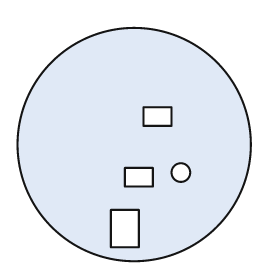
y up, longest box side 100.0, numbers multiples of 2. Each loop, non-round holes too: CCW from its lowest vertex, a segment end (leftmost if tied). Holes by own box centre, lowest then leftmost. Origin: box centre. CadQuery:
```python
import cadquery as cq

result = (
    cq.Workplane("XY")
    .moveTo(0.0, 0.0)
    .circle(50.0)
    .moveTo(-10.0, -44.0)
    .lineTo(2.0, -44.0)
    .lineTo(2.0, -28.0)
    .lineTo(-10.0, -28.0)
    .close()
    .moveTo(-4.0, -18.0)
    .lineTo(8.0, -18.0)
    .lineTo(8.0, -10.0)
    .lineTo(-4.0, -10.0)
    .close()
    .moveTo(20.0, -12.0)
    .circle(4.0)
    .moveTo(4.0, 8.0)
    .lineTo(16.0, 8.0)
    .lineTo(16.0, 16.0)
    .lineTo(4.0, 16.0)
    .close()
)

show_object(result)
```